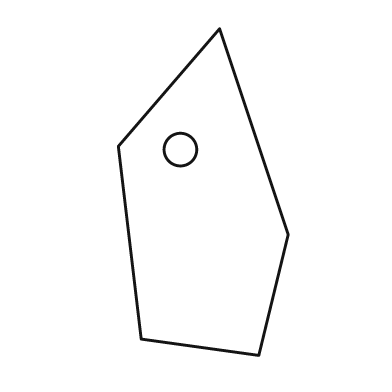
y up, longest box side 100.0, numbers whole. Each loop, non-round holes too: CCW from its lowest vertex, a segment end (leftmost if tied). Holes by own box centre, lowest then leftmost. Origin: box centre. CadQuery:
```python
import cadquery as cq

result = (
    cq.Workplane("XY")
    .moveTo(17.0, -50.0)
    .lineTo(26.0, -13.0)
    .lineTo(5.0, 50.0)
    .lineTo(-26.0, 14.0)
    .lineTo(-19.0, -45.0)
    .close()
    .moveTo(-7.0, 13.0)
    .circle(5.0)
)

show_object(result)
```